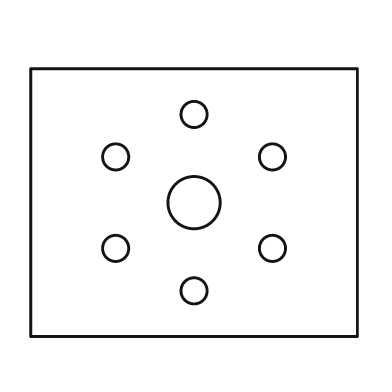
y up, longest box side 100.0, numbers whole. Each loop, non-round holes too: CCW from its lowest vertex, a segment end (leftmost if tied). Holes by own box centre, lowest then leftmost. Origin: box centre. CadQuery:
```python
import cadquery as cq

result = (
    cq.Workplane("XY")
    .moveTo(-50.0, -41.0)
    .lineTo(50.0, -41.0)
    .lineTo(50.0, 41.0)
    .lineTo(-50.0, 41.0)
    .close()
    .moveTo(0.0, -27.0)
    .circle(4.0)
    .moveTo(-24.0, -14.0)
    .circle(4.0)
    .moveTo(24.0, -14.0)
    .circle(4.0)
    .moveTo(0.0, 0.0)
    .circle(8.0)
    .moveTo(-24.0, 14.0)
    .circle(4.0)
    .moveTo(24.0, 14.0)
    .circle(4.0)
    .moveTo(0.0, 27.0)
    .circle(4.0)
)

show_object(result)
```